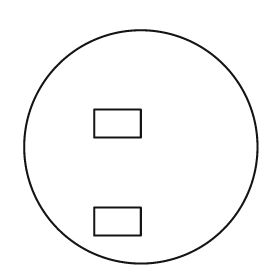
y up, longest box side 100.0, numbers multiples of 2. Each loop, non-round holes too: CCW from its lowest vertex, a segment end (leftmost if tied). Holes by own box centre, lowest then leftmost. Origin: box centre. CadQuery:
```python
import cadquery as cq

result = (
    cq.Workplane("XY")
    .moveTo(0.0, 0.0)
    .circle(50.0)
    .moveTo(-20.0, -38.0)
    .lineTo(0.0, -38.0)
    .lineTo(0.0, -26.0)
    .lineTo(-20.0, -26.0)
    .close()
    .moveTo(-20.0, 4.0)
    .lineTo(0.0, 4.0)
    .lineTo(0.0, 16.0)
    .lineTo(-20.0, 16.0)
    .close()
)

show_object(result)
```